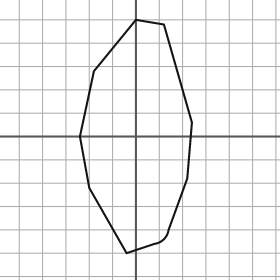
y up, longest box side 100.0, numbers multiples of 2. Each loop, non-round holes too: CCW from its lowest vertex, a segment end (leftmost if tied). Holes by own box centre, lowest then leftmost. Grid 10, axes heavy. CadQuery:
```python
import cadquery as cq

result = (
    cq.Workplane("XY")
    .moveTo(-4.0, -50.0)
    .lineTo(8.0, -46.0)
    .threePointArc((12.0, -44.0), (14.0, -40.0))
    .lineTo(22.0, -18.0)
    .lineTo(24.0, 6.0)
    .lineTo(12.0, 48.0)
    .lineTo(0.0, 50.0)
    .lineTo(-18.0, 28.0)
    .lineTo(-24.0, 0.0)
    .lineTo(-20.0, -22.0)
    .close()
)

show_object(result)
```